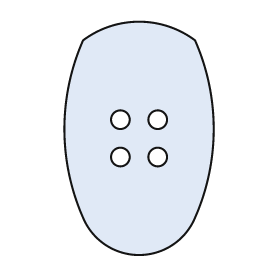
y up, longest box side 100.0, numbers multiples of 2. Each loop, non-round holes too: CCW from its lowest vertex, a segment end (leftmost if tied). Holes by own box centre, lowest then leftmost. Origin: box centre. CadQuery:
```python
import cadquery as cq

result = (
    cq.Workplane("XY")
    .moveTo(-24.0, -34.0)
    .threePointArc((0.0, -50.0), (24.0, -34.0))
    .threePointArc((32.0, 4.0), (24.0, 42.0))
    .threePointArc((0.0, 50.0), (-24.0, 42.0))
    .threePointArc((-32.0, 4.0), (-24.0, -34.0))
    .close()
    .moveTo(-8.0, -8.0)
    .circle(4.0)
    .moveTo(8.0, -8.0)
    .circle(4.0)
    .moveTo(-8.0, 8.0)
    .circle(4.0)
    .moveTo(8.0, 8.0)
    .circle(4.0)
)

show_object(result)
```